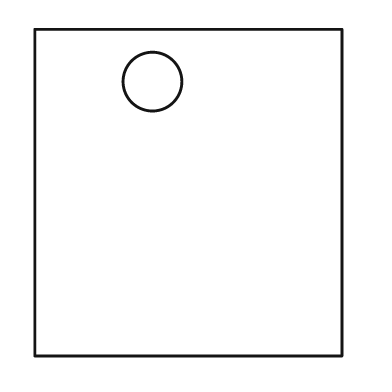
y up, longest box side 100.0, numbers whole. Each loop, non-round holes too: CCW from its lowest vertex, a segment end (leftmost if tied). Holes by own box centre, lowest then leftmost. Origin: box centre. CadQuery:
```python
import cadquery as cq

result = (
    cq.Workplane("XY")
    .moveTo(-47.0, -50.0)
    .lineTo(47.0, -50.0)
    .lineTo(47.0, 50.0)
    .lineTo(-47.0, 50.0)
    .close()
    .moveTo(-11.0, 34.0)
    .circle(9.0)
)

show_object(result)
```